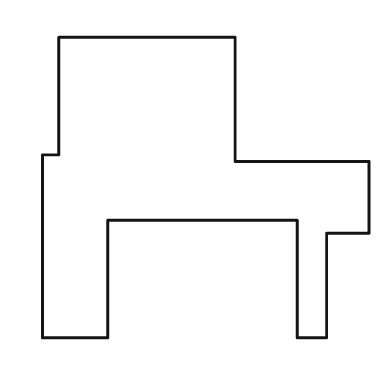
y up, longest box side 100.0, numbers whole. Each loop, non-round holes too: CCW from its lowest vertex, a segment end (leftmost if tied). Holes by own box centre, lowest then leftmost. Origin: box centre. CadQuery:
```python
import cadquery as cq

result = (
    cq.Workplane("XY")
    .moveTo(-50.0, -46.0)
    .lineTo(-30.0, -46.0)
    .lineTo(-30.0, -10.0)
    .lineTo(28.0, -10.0)
    .lineTo(28.0, -46.0)
    .lineTo(37.0, -46.0)
    .lineTo(37.0, -14.0)
    .lineTo(50.0, -14.0)
    .lineTo(50.0, 8.0)
    .lineTo(9.0, 8.0)
    .lineTo(9.0, 46.0)
    .lineTo(-45.0, 46.0)
    .lineTo(-45.0, 10.0)
    .lineTo(-50.0, 10.0)
    .close()
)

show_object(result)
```